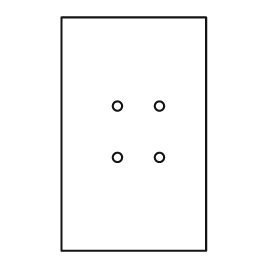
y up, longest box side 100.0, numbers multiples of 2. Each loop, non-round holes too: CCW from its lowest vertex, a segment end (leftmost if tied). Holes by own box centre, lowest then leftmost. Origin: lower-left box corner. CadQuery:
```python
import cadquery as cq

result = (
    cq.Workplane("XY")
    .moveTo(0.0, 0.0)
    .lineTo(62.0, 0.0)
    .lineTo(62.0, 100.0)
    .lineTo(0.0, 100.0)
    .close()
    .moveTo(24.0, 40.0)
    .circle(2.0)
    .moveTo(42.0, 40.0)
    .circle(2.0)
    .moveTo(24.0, 62.0)
    .circle(2.0)
    .moveTo(42.0, 62.0)
    .circle(2.0)
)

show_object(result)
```